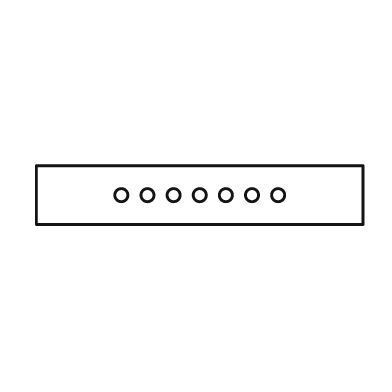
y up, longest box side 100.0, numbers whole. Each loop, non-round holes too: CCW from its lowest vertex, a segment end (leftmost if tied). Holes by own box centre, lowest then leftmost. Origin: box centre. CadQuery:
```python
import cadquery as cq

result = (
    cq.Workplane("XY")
    .moveTo(-50.0, -9.0)
    .lineTo(50.0, -9.0)
    .lineTo(50.0, 9.0)
    .lineTo(-50.0, 9.0)
    .close()
    .moveTo(-24.0, 0.0)
    .circle(2.0)
    .moveTo(-16.0, 0.0)
    .circle(2.0)
    .moveTo(-8.0, 0.0)
    .circle(2.0)
    .moveTo(0.0, 0.0)
    .circle(2.0)
    .moveTo(8.0, 0.0)
    .circle(2.0)
    .moveTo(16.0, 0.0)
    .circle(2.0)
    .moveTo(24.0, 0.0)
    .circle(2.0)
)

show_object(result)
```